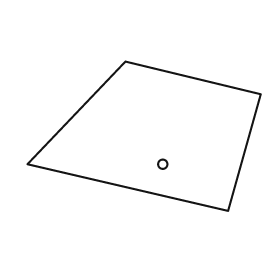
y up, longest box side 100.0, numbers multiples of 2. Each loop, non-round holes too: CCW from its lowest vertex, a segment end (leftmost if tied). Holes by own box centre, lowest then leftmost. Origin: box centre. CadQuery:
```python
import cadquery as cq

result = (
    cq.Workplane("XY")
    .moveTo(36.0, -32.0)
    .lineTo(50.0, 18.0)
    .lineTo(-8.0, 32.0)
    .lineTo(-50.0, -12.0)
    .close()
    .moveTo(8.0, -12.0)
    .circle(2.0)
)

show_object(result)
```